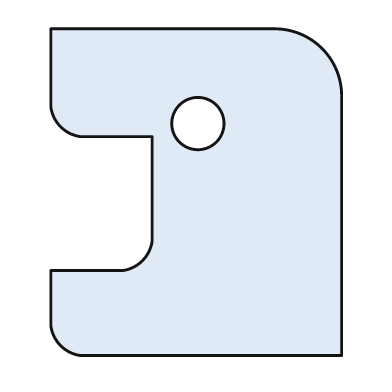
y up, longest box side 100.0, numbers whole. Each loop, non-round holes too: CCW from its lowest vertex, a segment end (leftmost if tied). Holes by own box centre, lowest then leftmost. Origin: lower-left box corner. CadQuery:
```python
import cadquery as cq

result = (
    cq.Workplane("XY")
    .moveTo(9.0, 0.0)
    .lineTo(89.0, 0.0)
    .lineTo(89.0, 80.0)
    .threePointArc((83.0, 94.0), (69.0, 100.0))
    .lineTo(0.0, 100.0)
    .lineTo(0.0, 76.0)
    .threePointArc((3.0, 70.0), (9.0, 67.0))
    .lineTo(31.0, 67.0)
    .lineTo(31.0, 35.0)
    .threePointArc((28.0, 29.0), (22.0, 26.0))
    .lineTo(0.0, 26.0)
    .lineTo(0.0, 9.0)
    .threePointArc((3.0, 3.0), (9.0, 0.0))
    .close()
    .moveTo(45.0, 71.0)
    .circle(8.0)
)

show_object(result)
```